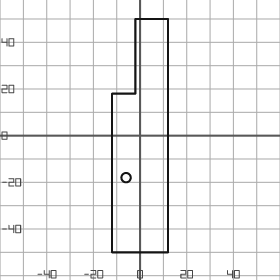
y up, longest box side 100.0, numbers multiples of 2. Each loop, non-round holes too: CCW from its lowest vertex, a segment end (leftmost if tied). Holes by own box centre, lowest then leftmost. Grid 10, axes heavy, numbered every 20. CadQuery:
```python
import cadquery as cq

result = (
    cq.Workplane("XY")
    .moveTo(-12.0, -50.0)
    .lineTo(12.0, -50.0)
    .lineTo(12.0, 50.0)
    .lineTo(-2.0, 50.0)
    .lineTo(-2.0, 18.0)
    .lineTo(-12.0, 18.0)
    .close()
    .moveTo(-6.0, -18.0)
    .circle(2.0)
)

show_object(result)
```